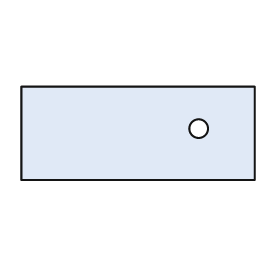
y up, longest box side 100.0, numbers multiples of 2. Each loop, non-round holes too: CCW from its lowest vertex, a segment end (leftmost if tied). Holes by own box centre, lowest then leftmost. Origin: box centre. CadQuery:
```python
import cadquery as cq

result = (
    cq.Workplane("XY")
    .moveTo(-50.0, -20.0)
    .lineTo(50.0, -20.0)
    .lineTo(50.0, 20.0)
    .lineTo(-50.0, 20.0)
    .close()
    .moveTo(26.0, 2.0)
    .circle(4.0)
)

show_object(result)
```